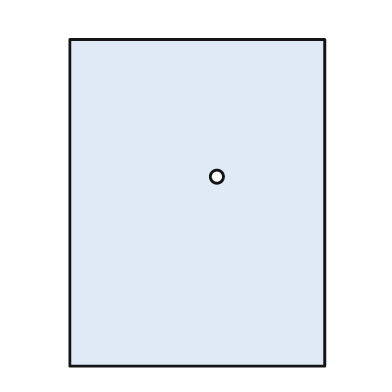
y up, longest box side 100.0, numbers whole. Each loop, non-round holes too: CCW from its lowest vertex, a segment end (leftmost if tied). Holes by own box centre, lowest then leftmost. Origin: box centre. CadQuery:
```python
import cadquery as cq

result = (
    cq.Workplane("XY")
    .moveTo(-39.0, -50.0)
    .lineTo(39.0, -50.0)
    .lineTo(39.0, 50.0)
    .lineTo(-39.0, 50.0)
    .close()
    .moveTo(6.0, 8.0)
    .circle(2.0)
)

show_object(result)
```